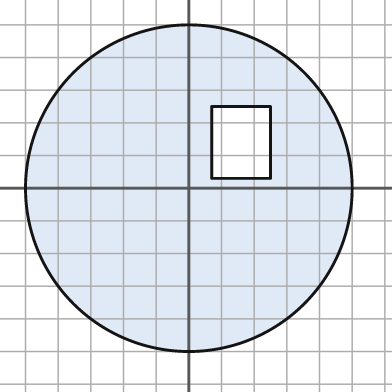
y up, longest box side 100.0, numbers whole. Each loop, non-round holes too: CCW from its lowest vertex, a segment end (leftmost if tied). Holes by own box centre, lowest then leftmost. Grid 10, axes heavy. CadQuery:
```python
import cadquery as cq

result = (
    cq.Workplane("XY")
    .moveTo(0.0, 0.0)
    .circle(50.0)
    .moveTo(7.0, 3.0)
    .lineTo(25.0, 3.0)
    .lineTo(25.0, 25.0)
    .lineTo(7.0, 25.0)
    .close()
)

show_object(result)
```